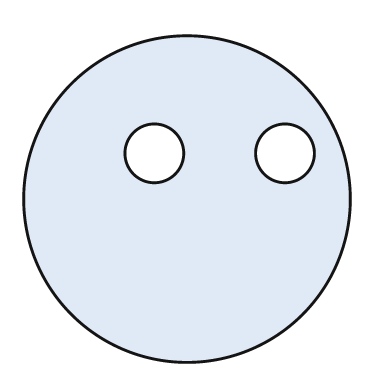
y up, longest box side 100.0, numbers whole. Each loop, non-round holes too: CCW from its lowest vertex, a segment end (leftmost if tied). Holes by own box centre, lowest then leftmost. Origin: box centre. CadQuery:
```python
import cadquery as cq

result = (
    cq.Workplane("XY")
    .moveTo(0.0, 0.0)
    .circle(50.0)
    .moveTo(-10.0, 14.0)
    .circle(9.0)
    .moveTo(30.0, 14.0)
    .circle(9.0)
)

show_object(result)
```